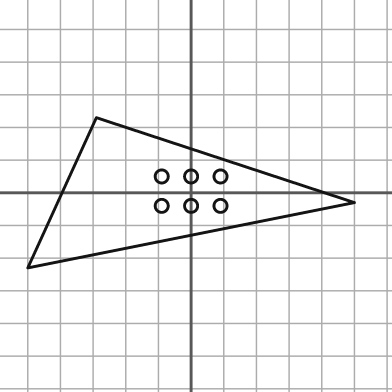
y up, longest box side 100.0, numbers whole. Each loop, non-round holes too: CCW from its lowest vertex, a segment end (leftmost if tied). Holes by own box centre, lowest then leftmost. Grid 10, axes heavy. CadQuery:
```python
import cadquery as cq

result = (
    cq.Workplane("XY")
    .moveTo(-50.0, -23.0)
    .lineTo(50.0, -3.0)
    .lineTo(-29.0, 23.0)
    .close()
    .moveTo(-9.0, -4.0)
    .circle(2.0)
    .moveTo(0.0, -4.0)
    .circle(2.0)
    .moveTo(9.0, -4.0)
    .circle(2.0)
    .moveTo(-9.0, 5.0)
    .circle(2.0)
    .moveTo(0.0, 5.0)
    .circle(2.0)
    .moveTo(9.0, 5.0)
    .circle(2.0)
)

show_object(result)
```